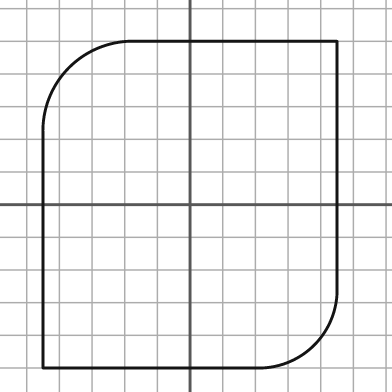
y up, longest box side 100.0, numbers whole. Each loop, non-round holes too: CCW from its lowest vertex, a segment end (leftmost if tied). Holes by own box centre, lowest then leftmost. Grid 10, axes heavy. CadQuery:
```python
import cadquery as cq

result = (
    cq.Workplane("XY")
    .moveTo(-45.0, -50.0)
    .lineTo(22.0, -50.0)
    .threePointArc((38.0, -43.0), (45.0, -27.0))
    .lineTo(45.0, 50.0)
    .lineTo(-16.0, 50.0)
    .threePointArc((-37.0, 42.0), (-45.0, 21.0))
    .close()
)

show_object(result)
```